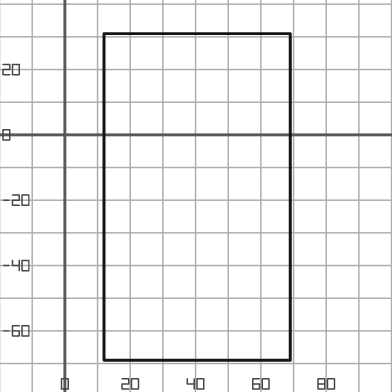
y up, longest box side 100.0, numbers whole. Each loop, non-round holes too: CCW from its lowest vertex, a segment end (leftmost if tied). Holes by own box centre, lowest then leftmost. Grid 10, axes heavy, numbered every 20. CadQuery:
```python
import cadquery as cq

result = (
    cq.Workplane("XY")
    .moveTo(12.0, -69.0)
    .lineTo(69.0, -69.0)
    .lineTo(69.0, 31.0)
    .lineTo(12.0, 31.0)
    .close()
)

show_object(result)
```